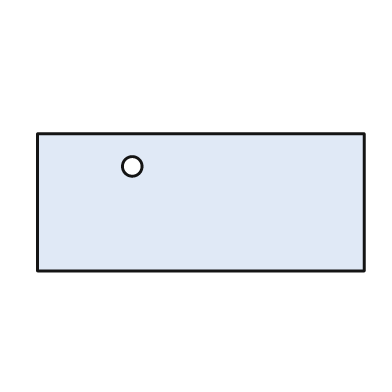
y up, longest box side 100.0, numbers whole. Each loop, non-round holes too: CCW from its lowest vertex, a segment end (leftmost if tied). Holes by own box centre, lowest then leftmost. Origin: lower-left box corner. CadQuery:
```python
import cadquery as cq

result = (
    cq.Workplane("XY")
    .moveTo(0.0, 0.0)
    .lineTo(100.0, 0.0)
    .lineTo(100.0, 42.0)
    .lineTo(0.0, 42.0)
    .close()
    .moveTo(29.0, 32.0)
    .circle(3.0)
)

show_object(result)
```